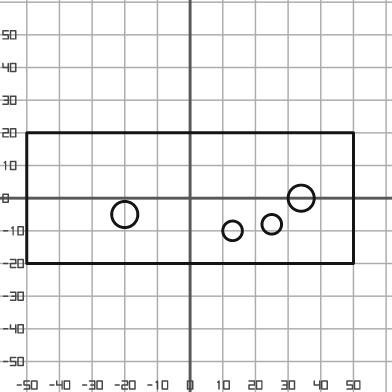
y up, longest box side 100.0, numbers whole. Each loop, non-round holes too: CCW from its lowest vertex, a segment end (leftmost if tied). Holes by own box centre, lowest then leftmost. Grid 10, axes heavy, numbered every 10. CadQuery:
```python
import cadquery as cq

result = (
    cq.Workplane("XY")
    .moveTo(-50.0, -20.0)
    .lineTo(50.0, -20.0)
    .lineTo(50.0, 20.0)
    .lineTo(-50.0, 20.0)
    .close()
    .moveTo(13.0, -10.0)
    .circle(3.0)
    .moveTo(25.0, -8.0)
    .circle(3.0)
    .moveTo(-20.0, -5.0)
    .circle(4.0)
    .moveTo(34.0, 0.0)
    .circle(4.0)
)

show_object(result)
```